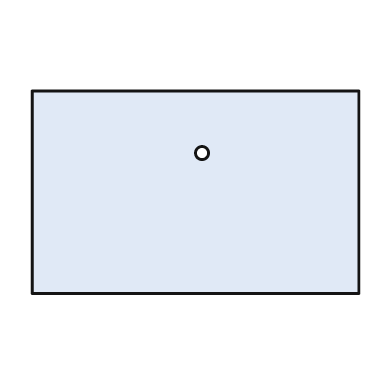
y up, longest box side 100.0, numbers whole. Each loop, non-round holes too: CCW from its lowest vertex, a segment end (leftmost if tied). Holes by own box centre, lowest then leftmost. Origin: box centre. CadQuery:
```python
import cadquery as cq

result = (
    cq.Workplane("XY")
    .moveTo(-50.0, -31.0)
    .lineTo(50.0, -31.0)
    .lineTo(50.0, 31.0)
    .lineTo(-50.0, 31.0)
    .close()
    .moveTo(2.0, 12.0)
    .circle(2.0)
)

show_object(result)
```